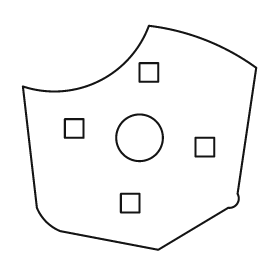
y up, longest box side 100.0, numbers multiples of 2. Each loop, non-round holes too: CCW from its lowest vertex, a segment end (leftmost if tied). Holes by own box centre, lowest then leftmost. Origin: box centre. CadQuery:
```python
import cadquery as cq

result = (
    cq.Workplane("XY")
    .moveTo(8.0, -48.0)
    .lineTo(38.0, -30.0)
    .threePointArc((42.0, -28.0), (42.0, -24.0))
    .lineTo(50.0, 30.0)
    .threePointArc((28.0, 42.0), (4.0, 48.0))
    .threePointArc((-18.0, 24.0), (-50.0, 22.0))
    .lineTo(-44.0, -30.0)
    .threePointArc((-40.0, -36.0), (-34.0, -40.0))
    .close()
    .moveTo(-8.0, -32.0)
    .lineTo(0.0, -32.0)
    .lineTo(0.0, -24.0)
    .lineTo(-8.0, -24.0)
    .close()
    .moveTo(24.0, -8.0)
    .lineTo(32.0, -8.0)
    .lineTo(32.0, 0.0)
    .lineTo(24.0, 0.0)
    .close()
    .moveTo(0.0, 0.0)
    .circle(10.0)
    .moveTo(-32.0, 0.0)
    .lineTo(-24.0, 0.0)
    .lineTo(-24.0, 8.0)
    .lineTo(-32.0, 8.0)
    .close()
    .moveTo(0.0, 24.0)
    .lineTo(8.0, 24.0)
    .lineTo(8.0, 32.0)
    .lineTo(0.0, 32.0)
    .close()
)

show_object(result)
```